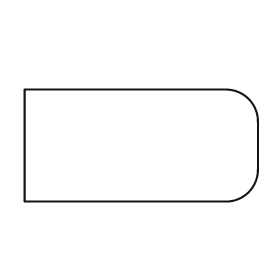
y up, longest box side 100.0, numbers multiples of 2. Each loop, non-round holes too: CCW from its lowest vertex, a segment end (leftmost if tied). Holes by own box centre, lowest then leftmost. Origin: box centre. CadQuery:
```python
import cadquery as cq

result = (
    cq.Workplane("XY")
    .moveTo(-50.0, -24.0)
    .lineTo(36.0, -24.0)
    .threePointArc((46.0, -20.0), (50.0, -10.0))
    .lineTo(50.0, 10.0)
    .threePointArc((46.0, 20.0), (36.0, 24.0))
    .lineTo(-50.0, 24.0)
    .close()
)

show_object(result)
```